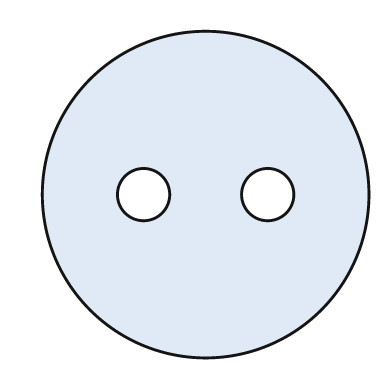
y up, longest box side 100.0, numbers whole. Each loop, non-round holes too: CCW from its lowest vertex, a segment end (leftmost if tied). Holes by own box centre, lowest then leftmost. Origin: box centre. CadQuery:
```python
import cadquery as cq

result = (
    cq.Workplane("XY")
    .moveTo(0.0, 0.0)
    .circle(50.0)
    .moveTo(-19.0, 0.0)
    .circle(8.0)
    .moveTo(19.0, 0.0)
    .circle(8.0)
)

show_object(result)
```